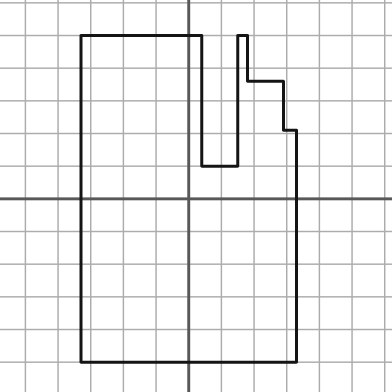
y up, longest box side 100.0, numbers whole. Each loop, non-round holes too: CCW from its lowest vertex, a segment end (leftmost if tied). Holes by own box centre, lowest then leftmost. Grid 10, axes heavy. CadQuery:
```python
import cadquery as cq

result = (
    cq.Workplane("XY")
    .moveTo(-33.0, -50.0)
    .lineTo(33.0, -50.0)
    .lineTo(33.0, 21.0)
    .lineTo(29.0, 21.0)
    .lineTo(29.0, 36.0)
    .lineTo(18.0, 36.0)
    .lineTo(18.0, 50.0)
    .lineTo(15.0, 50.0)
    .lineTo(15.0, 10.0)
    .lineTo(4.0, 10.0)
    .lineTo(4.0, 50.0)
    .lineTo(-33.0, 50.0)
    .close()
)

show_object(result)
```